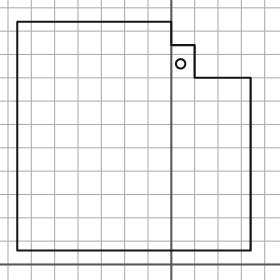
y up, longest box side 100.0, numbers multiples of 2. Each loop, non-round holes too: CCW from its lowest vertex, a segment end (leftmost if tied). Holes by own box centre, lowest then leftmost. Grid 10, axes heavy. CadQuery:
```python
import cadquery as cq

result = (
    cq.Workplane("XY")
    .moveTo(-66.0, 6.0)
    .lineTo(34.0, 6.0)
    .lineTo(34.0, 80.0)
    .lineTo(10.0, 80.0)
    .lineTo(10.0, 94.0)
    .lineTo(0.0, 94.0)
    .lineTo(0.0, 104.0)
    .lineTo(-66.0, 104.0)
    .close()
    .moveTo(4.0, 86.0)
    .circle(2.0)
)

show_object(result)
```